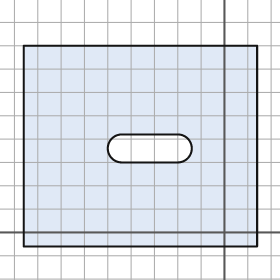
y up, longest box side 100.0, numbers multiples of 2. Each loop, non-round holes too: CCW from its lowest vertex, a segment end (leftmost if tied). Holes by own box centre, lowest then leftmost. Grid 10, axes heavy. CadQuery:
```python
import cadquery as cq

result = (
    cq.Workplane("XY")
    .moveTo(-86.0, -6.0)
    .lineTo(14.0, -6.0)
    .lineTo(14.0, 80.0)
    .lineTo(-86.0, 80.0)
    .close()
    .moveTo(-44.0, 30.0)
    .lineTo(-20.0, 30.0)
    .threePointArc((-14.0, 36.0), (-20.0, 42.0))
    .lineTo(-44.0, 42.0)
    .threePointArc((-50.0, 36.0), (-44.0, 30.0))
    .close()
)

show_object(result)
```